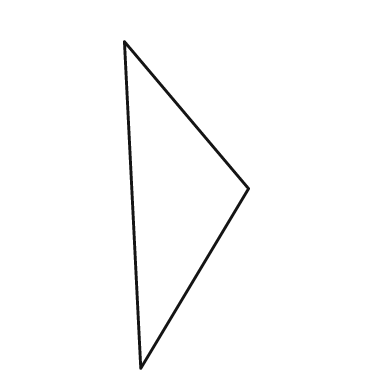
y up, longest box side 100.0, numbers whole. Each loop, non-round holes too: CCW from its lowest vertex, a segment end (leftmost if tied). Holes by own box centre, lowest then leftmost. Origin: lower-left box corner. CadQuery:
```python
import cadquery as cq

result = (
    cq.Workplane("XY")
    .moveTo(5.0, 0.0)
    .lineTo(38.0, 55.0)
    .lineTo(0.0, 100.0)
    .close()
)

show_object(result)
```